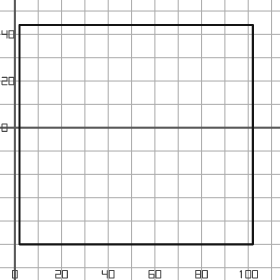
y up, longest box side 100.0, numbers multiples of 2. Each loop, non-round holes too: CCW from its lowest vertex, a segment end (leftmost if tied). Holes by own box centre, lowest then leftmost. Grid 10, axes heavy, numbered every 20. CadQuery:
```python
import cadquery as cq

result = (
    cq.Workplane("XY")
    .moveTo(2.0, -50.0)
    .lineTo(102.0, -50.0)
    .lineTo(102.0, 44.0)
    .lineTo(2.0, 44.0)
    .close()
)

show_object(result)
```